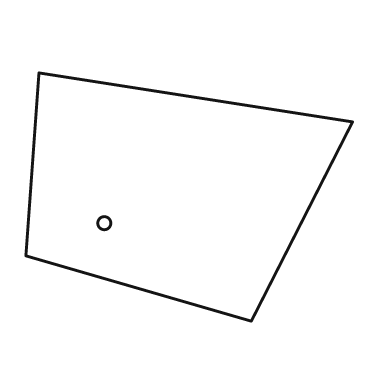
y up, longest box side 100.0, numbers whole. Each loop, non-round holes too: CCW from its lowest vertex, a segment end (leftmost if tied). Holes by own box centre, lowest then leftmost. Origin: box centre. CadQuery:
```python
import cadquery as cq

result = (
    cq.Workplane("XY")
    .moveTo(19.0, -38.0)
    .lineTo(50.0, 23.0)
    .lineTo(-46.0, 38.0)
    .lineTo(-50.0, -18.0)
    .close()
    .moveTo(-26.0, -8.0)
    .circle(2.0)
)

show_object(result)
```